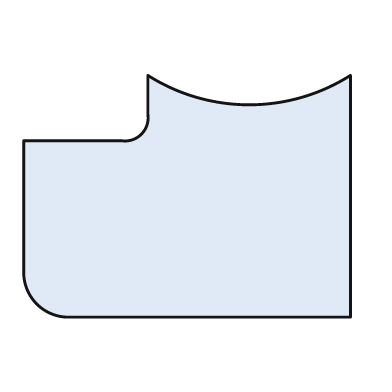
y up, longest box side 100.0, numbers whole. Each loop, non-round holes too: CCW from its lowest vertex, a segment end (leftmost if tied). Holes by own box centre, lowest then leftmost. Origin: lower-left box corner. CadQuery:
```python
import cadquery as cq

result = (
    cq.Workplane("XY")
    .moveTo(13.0, 0.0)
    .lineTo(100.0, 0.0)
    .lineTo(100.0, 74.0)
    .threePointArc((69.0, 65.0), (38.0, 74.0))
    .lineTo(38.0, 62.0)
    .threePointArc((36.0, 56.0), (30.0, 54.0))
    .lineTo(0.0, 54.0)
    .lineTo(0.0, 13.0)
    .threePointArc((4.0, 4.0), (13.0, 0.0))
    .close()
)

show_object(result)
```